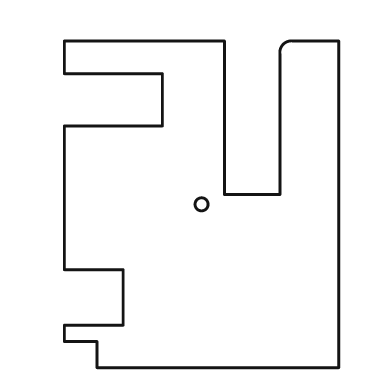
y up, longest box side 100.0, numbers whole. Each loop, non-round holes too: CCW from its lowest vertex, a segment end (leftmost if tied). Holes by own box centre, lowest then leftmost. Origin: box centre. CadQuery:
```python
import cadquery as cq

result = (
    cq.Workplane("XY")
    .moveTo(-32.0, -50.0)
    .lineTo(42.0, -50.0)
    .lineTo(42.0, 50.0)
    .lineTo(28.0, 50.0)
    .threePointArc((25.0, 49.0), (24.0, 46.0))
    .lineTo(24.0, 3.0)
    .lineTo(7.0, 3.0)
    .lineTo(7.0, 50.0)
    .lineTo(-42.0, 50.0)
    .lineTo(-42.0, 40.0)
    .lineTo(-12.0, 40.0)
    .lineTo(-12.0, 24.0)
    .lineTo(-42.0, 24.0)
    .lineTo(-42.0, -20.0)
    .lineTo(-24.0, -20.0)
    .lineTo(-24.0, -37.0)
    .lineTo(-42.0, -37.0)
    .lineTo(-42.0, -42.0)
    .lineTo(-32.0, -42.0)
    .close()
    .moveTo(0.0, 0.0)
    .circle(2.0)
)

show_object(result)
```